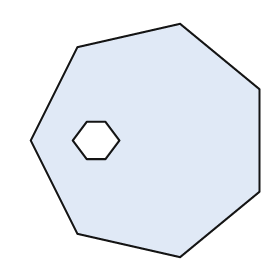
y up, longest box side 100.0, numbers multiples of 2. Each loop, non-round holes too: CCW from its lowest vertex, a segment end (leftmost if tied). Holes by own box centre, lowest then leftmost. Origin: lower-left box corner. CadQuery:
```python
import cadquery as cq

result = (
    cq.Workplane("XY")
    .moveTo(64.0, 0.0)
    .lineTo(98.0, 28.0)
    .lineTo(98.0, 72.0)
    .lineTo(64.0, 100.0)
    .lineTo(20.0, 90.0)
    .lineTo(0.0, 50.0)
    .lineTo(20.0, 10.0)
    .close()
    .moveTo(24.0, 42.0)
    .lineTo(32.0, 42.0)
    .lineTo(38.0, 50.0)
    .lineTo(32.0, 58.0)
    .lineTo(24.0, 58.0)
    .lineTo(18.0, 50.0)
    .close()
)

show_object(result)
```